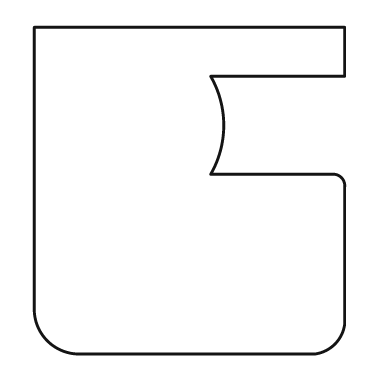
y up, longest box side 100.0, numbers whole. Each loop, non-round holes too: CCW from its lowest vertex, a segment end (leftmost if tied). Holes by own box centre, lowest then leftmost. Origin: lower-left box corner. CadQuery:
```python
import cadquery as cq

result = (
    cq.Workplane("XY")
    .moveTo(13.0, 0.0)
    .lineTo(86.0, 0.0)
    .threePointArc((92.0, 3.0), (95.0, 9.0))
    .lineTo(95.0, 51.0)
    .threePointArc((94.0, 54.0), (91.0, 55.0))
    .lineTo(54.0, 55.0)
    .threePointArc((58.0, 70.0), (54.0, 85.0))
    .lineTo(95.0, 85.0)
    .lineTo(95.0, 100.0)
    .lineTo(0.0, 100.0)
    .lineTo(0.0, 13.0)
    .threePointArc((4.0, 4.0), (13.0, 0.0))
    .close()
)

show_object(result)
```